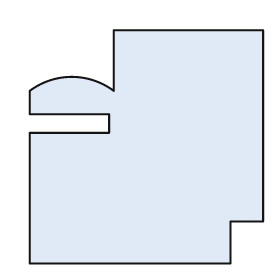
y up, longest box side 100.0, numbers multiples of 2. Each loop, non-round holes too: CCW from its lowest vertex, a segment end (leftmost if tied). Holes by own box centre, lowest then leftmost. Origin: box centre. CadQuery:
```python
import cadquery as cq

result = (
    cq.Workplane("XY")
    .moveTo(-50.0, -50.0)
    .lineTo(36.0, -50.0)
    .lineTo(36.0, -32.0)
    .lineTo(50.0, -32.0)
    .lineTo(50.0, 50.0)
    .lineTo(-14.0, 50.0)
    .lineTo(-14.0, 24.0)
    .threePointArc((-32.0, 30.0), (-50.0, 24.0))
    .lineTo(-50.0, 14.0)
    .lineTo(-16.0, 14.0)
    .lineTo(-16.0, 6.0)
    .lineTo(-50.0, 6.0)
    .close()
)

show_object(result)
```